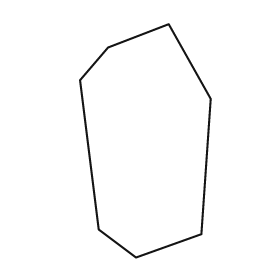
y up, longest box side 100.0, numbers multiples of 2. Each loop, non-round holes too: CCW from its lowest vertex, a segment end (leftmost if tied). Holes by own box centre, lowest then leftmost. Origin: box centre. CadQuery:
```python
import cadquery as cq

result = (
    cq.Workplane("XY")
    .moveTo(-4.0, -50.0)
    .lineTo(24.0, -40.0)
    .lineTo(28.0, 18.0)
    .lineTo(10.0, 50.0)
    .lineTo(-16.0, 40.0)
    .lineTo(-28.0, 26.0)
    .lineTo(-20.0, -38.0)
    .close()
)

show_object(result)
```